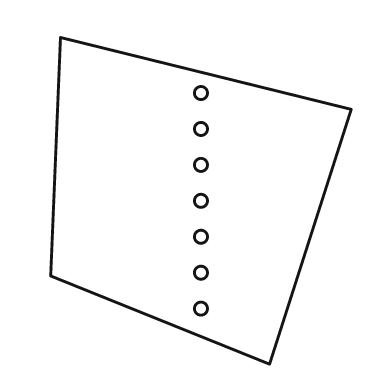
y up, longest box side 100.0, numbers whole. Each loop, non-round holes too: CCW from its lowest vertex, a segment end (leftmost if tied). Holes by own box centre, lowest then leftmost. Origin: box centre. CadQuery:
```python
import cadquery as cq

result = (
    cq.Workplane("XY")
    .moveTo(21.0, -50.0)
    .lineTo(46.0, 28.0)
    .lineTo(-43.0, 50.0)
    .lineTo(-46.0, -23.0)
    .close()
    .moveTo(0.0, -33.0)
    .circle(2.0)
    .moveTo(0.0, -22.0)
    .circle(2.0)
    .moveTo(0.0, -11.0)
    .circle(2.0)
    .moveTo(0.0, 0.0)
    .circle(2.0)
    .moveTo(0.0, 11.0)
    .circle(2.0)
    .moveTo(0.0, 22.0)
    .circle(2.0)
    .moveTo(0.0, 33.0)
    .circle(2.0)
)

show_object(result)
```